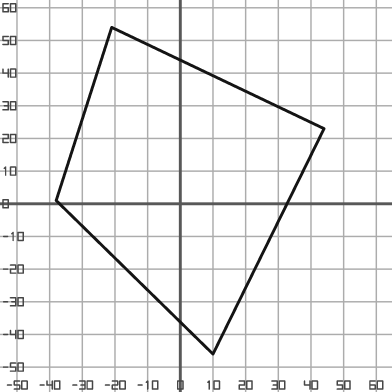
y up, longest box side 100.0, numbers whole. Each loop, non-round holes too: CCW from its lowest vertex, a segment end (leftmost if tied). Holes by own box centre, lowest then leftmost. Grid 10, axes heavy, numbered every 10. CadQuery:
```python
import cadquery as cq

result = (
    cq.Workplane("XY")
    .moveTo(10.0, -46.0)
    .lineTo(44.0, 23.0)
    .lineTo(-21.0, 54.0)
    .lineTo(-38.0, 1.0)
    .close()
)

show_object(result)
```